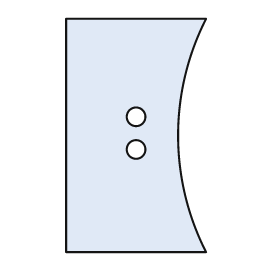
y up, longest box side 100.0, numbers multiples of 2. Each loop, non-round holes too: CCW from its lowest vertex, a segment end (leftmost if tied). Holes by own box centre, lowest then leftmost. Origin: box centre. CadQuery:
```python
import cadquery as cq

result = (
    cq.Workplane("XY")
    .moveTo(-30.0, -50.0)
    .lineTo(30.0, -50.0)
    .threePointArc((18.0, 0.0), (30.0, 50.0))
    .lineTo(-30.0, 50.0)
    .close()
    .moveTo(0.0, -6.0)
    .circle(4.0)
    .moveTo(0.0, 8.0)
    .circle(4.0)
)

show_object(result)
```